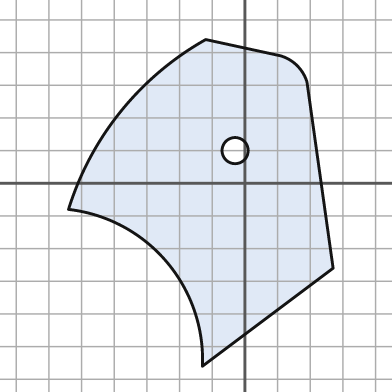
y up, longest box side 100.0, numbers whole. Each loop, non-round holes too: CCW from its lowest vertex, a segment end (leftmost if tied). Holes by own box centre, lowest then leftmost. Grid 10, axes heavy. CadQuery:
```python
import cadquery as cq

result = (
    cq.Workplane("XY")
    .moveTo(-13.0, -56.0)
    .lineTo(27.0, -26.0)
    .lineTo(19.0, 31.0)
    .threePointArc((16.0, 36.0), (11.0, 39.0))
    .lineTo(-12.0, 44.0)
    .threePointArc((-38.0, 22.0), (-54.0, -8.0))
    .threePointArc((-24.0, -24.0), (-13.0, -56.0))
    .close()
    .moveTo(-3.0, 10.0)
    .circle(4.0)
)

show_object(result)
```